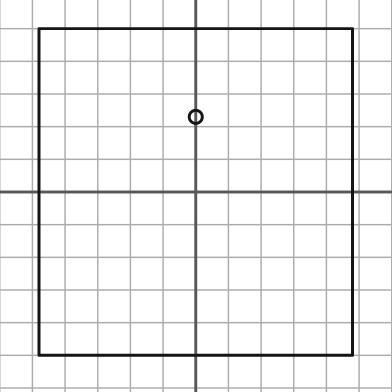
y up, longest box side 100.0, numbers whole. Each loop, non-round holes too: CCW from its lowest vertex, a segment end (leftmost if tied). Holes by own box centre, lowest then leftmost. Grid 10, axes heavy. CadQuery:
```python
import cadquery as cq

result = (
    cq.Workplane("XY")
    .moveTo(-48.0, -50.0)
    .lineTo(48.0, -50.0)
    .lineTo(48.0, 50.0)
    .lineTo(-48.0, 50.0)
    .close()
    .moveTo(0.0, 23.0)
    .circle(2.0)
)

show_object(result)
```